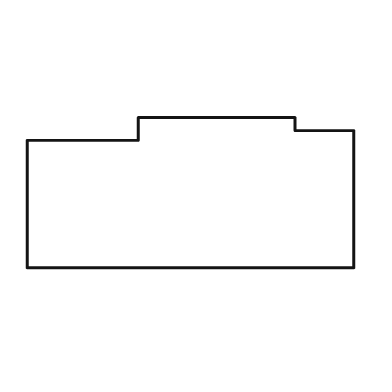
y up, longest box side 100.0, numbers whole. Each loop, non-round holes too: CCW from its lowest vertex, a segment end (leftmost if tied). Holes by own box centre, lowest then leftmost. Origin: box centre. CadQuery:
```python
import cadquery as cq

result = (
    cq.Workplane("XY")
    .moveTo(-50.0, -23.0)
    .lineTo(50.0, -23.0)
    .lineTo(50.0, 19.0)
    .lineTo(32.0, 19.0)
    .lineTo(32.0, 23.0)
    .lineTo(-16.0, 23.0)
    .lineTo(-16.0, 16.0)
    .lineTo(-50.0, 16.0)
    .close()
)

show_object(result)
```